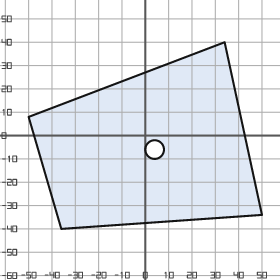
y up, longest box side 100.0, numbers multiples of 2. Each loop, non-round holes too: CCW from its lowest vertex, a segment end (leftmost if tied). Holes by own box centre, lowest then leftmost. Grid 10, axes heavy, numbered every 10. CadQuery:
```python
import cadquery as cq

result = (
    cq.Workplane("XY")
    .moveTo(-36.0, -40.0)
    .lineTo(50.0, -34.0)
    .lineTo(34.0, 40.0)
    .lineTo(-50.0, 8.0)
    .close()
    .moveTo(4.0, -6.0)
    .circle(4.0)
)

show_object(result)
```